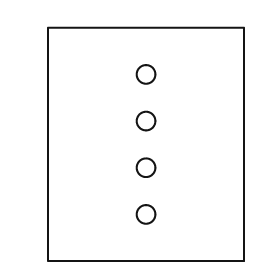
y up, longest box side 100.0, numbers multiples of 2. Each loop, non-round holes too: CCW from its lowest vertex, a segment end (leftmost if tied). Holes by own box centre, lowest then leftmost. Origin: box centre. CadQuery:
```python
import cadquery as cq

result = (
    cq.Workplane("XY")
    .moveTo(-42.0, -50.0)
    .lineTo(42.0, -50.0)
    .lineTo(42.0, 50.0)
    .lineTo(-42.0, 50.0)
    .close()
    .moveTo(0.0, -30.0)
    .circle(4.0)
    .moveTo(0.0, -10.0)
    .circle(4.0)
    .moveTo(0.0, 10.0)
    .circle(4.0)
    .moveTo(0.0, 30.0)
    .circle(4.0)
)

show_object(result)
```